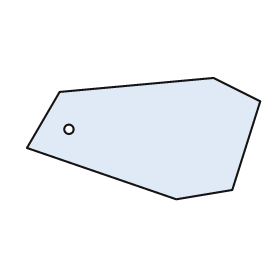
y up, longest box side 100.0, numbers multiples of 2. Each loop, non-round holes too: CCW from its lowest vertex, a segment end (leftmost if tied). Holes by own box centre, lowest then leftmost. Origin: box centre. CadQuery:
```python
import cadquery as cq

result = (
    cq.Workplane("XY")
    .moveTo(14.0, -26.0)
    .lineTo(38.0, -22.0)
    .lineTo(50.0, 16.0)
    .lineTo(30.0, 26.0)
    .lineTo(-36.0, 20.0)
    .lineTo(-50.0, -4.0)
    .close()
    .moveTo(-32.0, 4.0)
    .circle(2.0)
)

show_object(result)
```